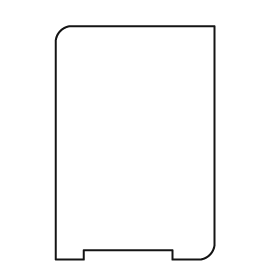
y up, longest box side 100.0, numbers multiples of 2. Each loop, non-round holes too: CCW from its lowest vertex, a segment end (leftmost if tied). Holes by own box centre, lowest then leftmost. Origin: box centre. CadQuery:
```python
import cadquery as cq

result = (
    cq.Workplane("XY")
    .moveTo(-34.0, -50.0)
    .lineTo(-22.0, -50.0)
    .lineTo(-22.0, -46.0)
    .lineTo(16.0, -46.0)
    .lineTo(16.0, -50.0)
    .lineTo(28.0, -50.0)
    .threePointArc((32.0, -48.0), (34.0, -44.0))
    .lineTo(34.0, 50.0)
    .lineTo(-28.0, 50.0)
    .threePointArc((-32.0, 48.0), (-34.0, 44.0))
    .close()
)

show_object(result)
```